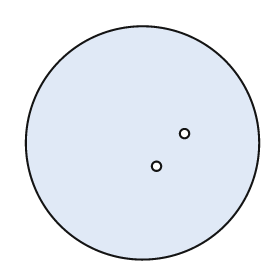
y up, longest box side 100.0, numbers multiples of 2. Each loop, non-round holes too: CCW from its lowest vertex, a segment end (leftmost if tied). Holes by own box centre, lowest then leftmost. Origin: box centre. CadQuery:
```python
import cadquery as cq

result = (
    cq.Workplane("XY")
    .moveTo(0.0, 0.0)
    .circle(50.0)
    .moveTo(6.0, -10.0)
    .circle(2.0)
    .moveTo(18.0, 4.0)
    .circle(2.0)
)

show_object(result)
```